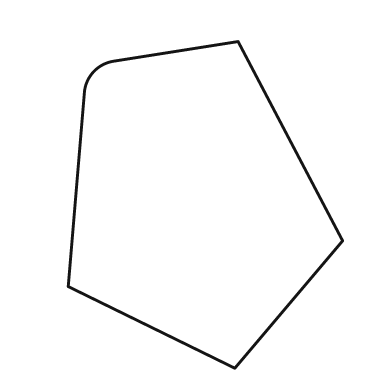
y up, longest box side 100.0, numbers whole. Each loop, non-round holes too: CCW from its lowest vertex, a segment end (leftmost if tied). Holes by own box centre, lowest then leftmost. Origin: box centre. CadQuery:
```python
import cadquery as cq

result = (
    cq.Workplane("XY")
    .moveTo(9.0, -50.0)
    .lineTo(42.0, -11.0)
    .lineTo(10.0, 50.0)
    .lineTo(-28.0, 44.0)
    .threePointArc((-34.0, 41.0), (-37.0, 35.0))
    .lineTo(-42.0, -25.0)
    .close()
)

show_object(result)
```